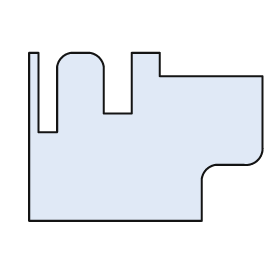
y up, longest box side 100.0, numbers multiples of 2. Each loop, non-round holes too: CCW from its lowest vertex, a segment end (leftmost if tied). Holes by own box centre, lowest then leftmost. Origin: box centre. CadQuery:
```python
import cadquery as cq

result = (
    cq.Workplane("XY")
    .moveTo(-50.0, -36.0)
    .lineTo(24.0, -36.0)
    .lineTo(24.0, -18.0)
    .threePointArc((26.0, -14.0), (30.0, -12.0))
    .lineTo(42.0, -12.0)
    .threePointArc((48.0, -10.0), (50.0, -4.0))
    .lineTo(50.0, 26.0)
    .lineTo(6.0, 26.0)
    .lineTo(6.0, 36.0)
    .lineTo(-6.0, 36.0)
    .lineTo(-6.0, 10.0)
    .lineTo(-18.0, 10.0)
    .lineTo(-18.0, 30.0)
    .threePointArc((-20.0, 34.0), (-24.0, 36.0))
    .lineTo(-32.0, 36.0)
    .threePointArc((-36.0, 34.0), (-38.0, 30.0))
    .lineTo(-38.0, 2.0)
    .lineTo(-46.0, 2.0)
    .lineTo(-46.0, 36.0)
    .lineTo(-50.0, 36.0)
    .close()
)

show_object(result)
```